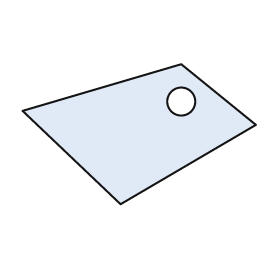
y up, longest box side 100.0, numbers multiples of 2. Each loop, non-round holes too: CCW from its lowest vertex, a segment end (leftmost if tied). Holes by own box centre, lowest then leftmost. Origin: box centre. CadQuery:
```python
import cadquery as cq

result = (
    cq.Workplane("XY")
    .moveTo(-8.0, -30.0)
    .lineTo(50.0, 4.0)
    .lineTo(18.0, 30.0)
    .lineTo(-50.0, 10.0)
    .close()
    .moveTo(18.0, 14.0)
    .circle(6.0)
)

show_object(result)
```